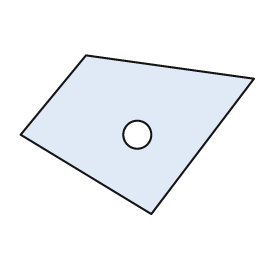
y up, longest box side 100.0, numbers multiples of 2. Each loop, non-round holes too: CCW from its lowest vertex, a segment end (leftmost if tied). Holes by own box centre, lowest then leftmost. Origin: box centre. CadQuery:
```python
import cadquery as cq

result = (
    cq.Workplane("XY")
    .moveTo(6.0, -34.0)
    .lineTo(50.0, 24.0)
    .lineTo(-22.0, 34.0)
    .lineTo(-50.0, 0.0)
    .close()
    .moveTo(0.0, 0.0)
    .circle(6.0)
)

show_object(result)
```